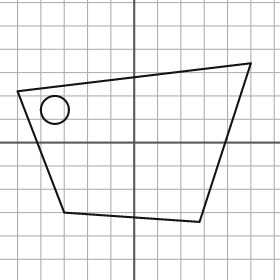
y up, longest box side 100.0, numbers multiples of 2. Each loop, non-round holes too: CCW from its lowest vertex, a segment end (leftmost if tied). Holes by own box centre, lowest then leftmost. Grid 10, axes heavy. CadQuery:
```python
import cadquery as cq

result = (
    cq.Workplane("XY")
    .moveTo(28.0, -34.0)
    .lineTo(50.0, 34.0)
    .lineTo(-50.0, 22.0)
    .lineTo(-30.0, -30.0)
    .close()
    .moveTo(-34.0, 14.0)
    .circle(6.0)
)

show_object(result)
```